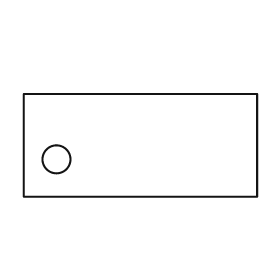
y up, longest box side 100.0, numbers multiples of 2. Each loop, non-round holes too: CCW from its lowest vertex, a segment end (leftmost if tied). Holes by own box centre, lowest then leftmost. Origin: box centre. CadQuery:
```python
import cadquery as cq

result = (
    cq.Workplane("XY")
    .moveTo(-50.0, -22.0)
    .lineTo(50.0, -22.0)
    .lineTo(50.0, 22.0)
    .lineTo(-50.0, 22.0)
    .close()
    .moveTo(-36.0, -6.0)
    .circle(6.0)
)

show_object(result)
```